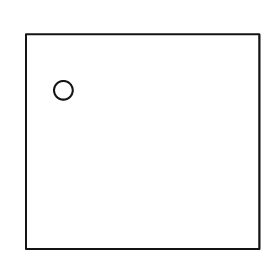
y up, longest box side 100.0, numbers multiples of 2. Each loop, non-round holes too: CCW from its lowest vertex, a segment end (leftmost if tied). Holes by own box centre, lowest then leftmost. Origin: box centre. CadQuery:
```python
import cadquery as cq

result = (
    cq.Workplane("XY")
    .moveTo(-50.0, -46.0)
    .lineTo(50.0, -46.0)
    .lineTo(50.0, 46.0)
    .lineTo(-50.0, 46.0)
    .close()
    .moveTo(-34.0, 22.0)
    .circle(4.0)
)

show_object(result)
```